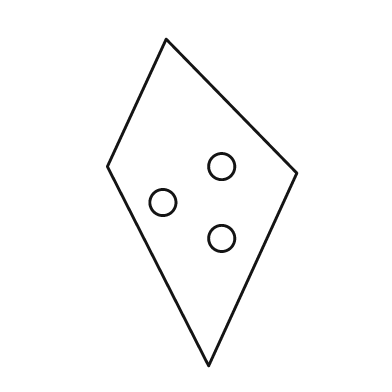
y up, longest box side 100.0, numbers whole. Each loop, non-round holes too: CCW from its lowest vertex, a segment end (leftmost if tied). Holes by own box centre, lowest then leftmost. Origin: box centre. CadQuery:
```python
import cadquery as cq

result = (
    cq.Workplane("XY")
    .moveTo(2.0, -50.0)
    .lineTo(29.0, 9.0)
    .lineTo(-11.0, 50.0)
    .lineTo(-29.0, 11.0)
    .close()
    .moveTo(6.0, -11.0)
    .circle(4.0)
    .moveTo(-12.0, 0.0)
    .circle(4.0)
    .moveTo(6.0, 11.0)
    .circle(4.0)
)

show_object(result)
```